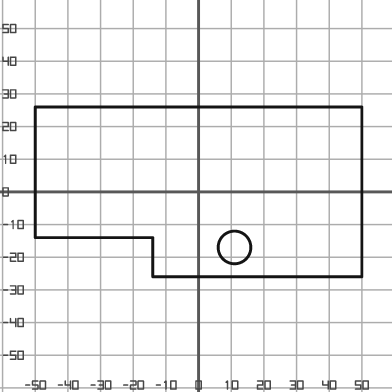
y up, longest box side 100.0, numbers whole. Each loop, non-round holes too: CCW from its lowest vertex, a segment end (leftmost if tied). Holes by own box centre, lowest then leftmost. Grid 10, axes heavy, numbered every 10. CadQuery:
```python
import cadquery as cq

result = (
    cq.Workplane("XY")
    .moveTo(-14.0, -26.0)
    .lineTo(50.0, -26.0)
    .lineTo(50.0, 26.0)
    .lineTo(-50.0, 26.0)
    .lineTo(-50.0, -14.0)
    .lineTo(-14.0, -14.0)
    .close()
    .moveTo(11.0, -17.0)
    .circle(5.0)
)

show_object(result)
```